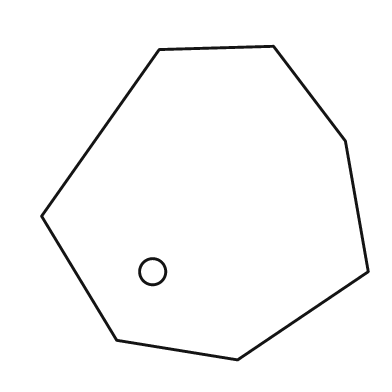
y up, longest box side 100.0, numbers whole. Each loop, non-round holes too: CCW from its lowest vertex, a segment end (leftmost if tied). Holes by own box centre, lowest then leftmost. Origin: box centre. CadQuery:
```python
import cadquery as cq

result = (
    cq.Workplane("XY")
    .moveTo(10.0, -48.0)
    .lineTo(50.0, -21.0)
    .lineTo(43.0, 19.0)
    .lineTo(21.0, 48.0)
    .lineTo(-14.0, 47.0)
    .lineTo(-50.0, -4.0)
    .lineTo(-27.0, -42.0)
    .close()
    .moveTo(-16.0, -21.0)
    .circle(4.0)
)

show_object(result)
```